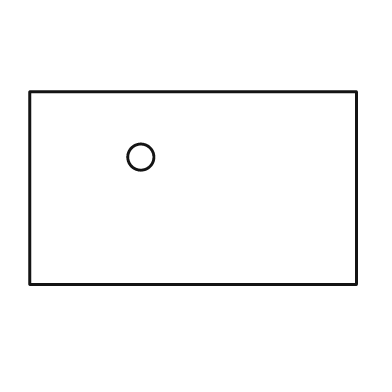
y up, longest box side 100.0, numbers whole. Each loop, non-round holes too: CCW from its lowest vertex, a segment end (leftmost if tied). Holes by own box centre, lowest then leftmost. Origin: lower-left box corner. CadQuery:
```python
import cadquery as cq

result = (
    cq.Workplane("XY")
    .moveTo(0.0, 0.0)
    .lineTo(100.0, 0.0)
    .lineTo(100.0, 59.0)
    .lineTo(0.0, 59.0)
    .close()
    .moveTo(34.0, 39.0)
    .circle(4.0)
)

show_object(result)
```